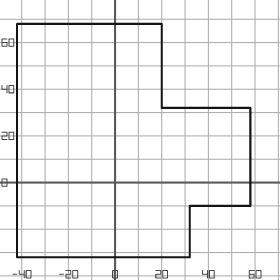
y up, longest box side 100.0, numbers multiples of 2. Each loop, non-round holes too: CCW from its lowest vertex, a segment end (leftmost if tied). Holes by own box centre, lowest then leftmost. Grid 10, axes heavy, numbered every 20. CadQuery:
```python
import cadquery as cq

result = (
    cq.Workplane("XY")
    .moveTo(-42.0, -32.0)
    .lineTo(32.0, -32.0)
    .lineTo(32.0, -10.0)
    .lineTo(58.0, -10.0)
    .lineTo(58.0, 32.0)
    .lineTo(20.0, 32.0)
    .lineTo(20.0, 68.0)
    .lineTo(-42.0, 68.0)
    .close()
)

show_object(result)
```